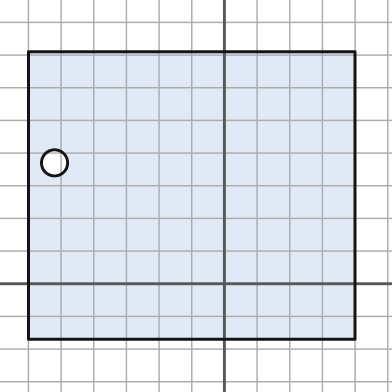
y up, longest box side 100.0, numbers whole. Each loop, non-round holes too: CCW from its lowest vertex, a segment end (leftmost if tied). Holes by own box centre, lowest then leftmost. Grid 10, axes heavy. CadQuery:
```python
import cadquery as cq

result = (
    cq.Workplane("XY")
    .moveTo(-60.0, -17.0)
    .lineTo(40.0, -17.0)
    .lineTo(40.0, 71.0)
    .lineTo(-60.0, 71.0)
    .close()
    .moveTo(-52.0, 37.0)
    .circle(4.0)
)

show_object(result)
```